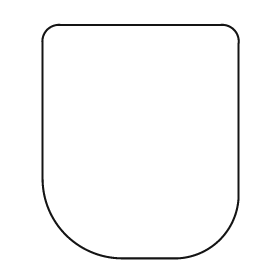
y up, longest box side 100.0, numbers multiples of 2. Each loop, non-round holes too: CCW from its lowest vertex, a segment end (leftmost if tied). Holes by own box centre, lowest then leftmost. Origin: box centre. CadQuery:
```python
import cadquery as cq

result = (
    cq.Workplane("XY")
    .moveTo(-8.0, -50.0)
    .lineTo(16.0, -50.0)
    .threePointArc((34.0, -42.0), (42.0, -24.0))
    .lineTo(42.0, 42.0)
    .threePointArc((40.0, 48.0), (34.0, 50.0))
    .lineTo(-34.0, 50.0)
    .threePointArc((-40.0, 48.0), (-42.0, 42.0))
    .lineTo(-42.0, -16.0)
    .threePointArc((-32.0, -40.0), (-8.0, -50.0))
    .close()
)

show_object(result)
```